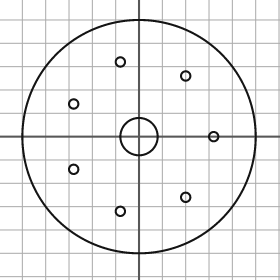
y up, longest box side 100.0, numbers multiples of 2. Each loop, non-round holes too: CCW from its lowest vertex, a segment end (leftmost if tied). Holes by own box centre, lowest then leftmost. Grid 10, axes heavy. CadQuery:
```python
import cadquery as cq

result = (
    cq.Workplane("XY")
    .moveTo(0.0, 0.0)
    .circle(50.0)
    .moveTo(-8.0, -32.0)
    .circle(2.0)
    .moveTo(20.0, -26.0)
    .circle(2.0)
    .moveTo(-28.0, -14.0)
    .circle(2.0)
    .moveTo(0.0, 0.0)
    .circle(8.0)
    .moveTo(32.0, 0.0)
    .circle(2.0)
    .moveTo(-28.0, 14.0)
    .circle(2.0)
    .moveTo(20.0, 26.0)
    .circle(2.0)
    .moveTo(-8.0, 32.0)
    .circle(2.0)
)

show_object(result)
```